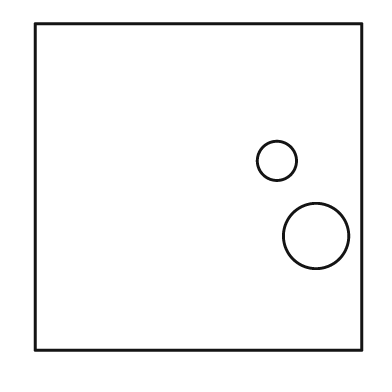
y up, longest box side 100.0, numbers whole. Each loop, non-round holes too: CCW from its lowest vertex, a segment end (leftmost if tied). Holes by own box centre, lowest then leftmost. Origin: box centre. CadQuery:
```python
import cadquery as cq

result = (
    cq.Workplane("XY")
    .moveTo(-50.0, -50.0)
    .lineTo(50.0, -50.0)
    .lineTo(50.0, 50.0)
    .lineTo(-50.0, 50.0)
    .close()
    .moveTo(36.0, -15.0)
    .circle(10.0)
    .moveTo(24.0, 8.0)
    .circle(6.0)
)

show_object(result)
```